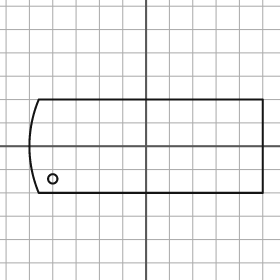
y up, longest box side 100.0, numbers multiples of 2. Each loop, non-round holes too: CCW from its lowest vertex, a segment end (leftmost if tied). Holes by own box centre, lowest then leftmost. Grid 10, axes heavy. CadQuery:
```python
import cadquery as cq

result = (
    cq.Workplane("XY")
    .moveTo(-46.0, -20.0)
    .lineTo(50.0, -20.0)
    .lineTo(50.0, 20.0)
    .lineTo(-46.0, 20.0)
    .threePointArc((-50.0, 0.0), (-46.0, -20.0))
    .close()
    .moveTo(-40.0, -14.0)
    .circle(2.0)
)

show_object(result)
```